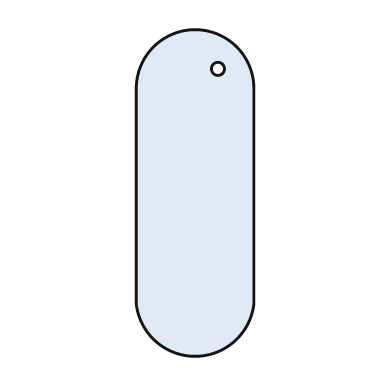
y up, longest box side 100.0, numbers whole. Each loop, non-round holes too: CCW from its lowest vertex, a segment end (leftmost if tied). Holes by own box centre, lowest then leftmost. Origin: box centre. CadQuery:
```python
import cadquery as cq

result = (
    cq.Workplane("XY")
    .moveTo(-18.0, -34.0)
    .threePointArc((0.0, -50.0), (18.0, -34.0))
    .lineTo(18.0, 32.0)
    .threePointArc((0.0, 50.0), (-18.0, 32.0))
    .close()
    .moveTo(7.0, 38.0)
    .circle(2.0)
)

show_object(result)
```